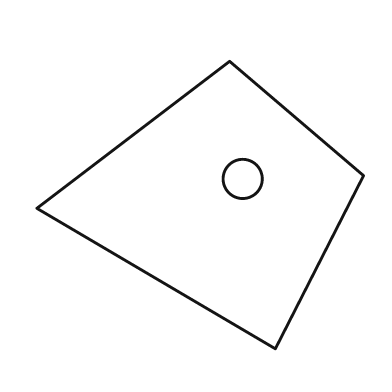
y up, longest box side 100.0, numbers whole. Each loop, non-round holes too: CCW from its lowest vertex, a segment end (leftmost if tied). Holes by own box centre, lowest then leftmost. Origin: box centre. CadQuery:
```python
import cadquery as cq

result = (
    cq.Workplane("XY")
    .moveTo(23.0, -44.0)
    .lineTo(50.0, 9.0)
    .lineTo(9.0, 44.0)
    .lineTo(-50.0, -1.0)
    .close()
    .moveTo(13.0, 8.0)
    .circle(6.0)
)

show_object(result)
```